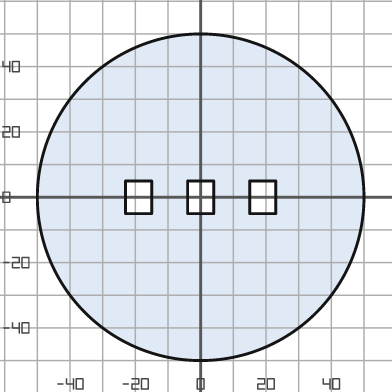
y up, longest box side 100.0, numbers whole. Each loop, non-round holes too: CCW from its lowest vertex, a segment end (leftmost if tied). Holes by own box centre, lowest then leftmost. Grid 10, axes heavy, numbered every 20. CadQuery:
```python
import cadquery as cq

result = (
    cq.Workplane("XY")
    .moveTo(0.0, 0.0)
    .circle(50.0)
    .moveTo(-23.0, -5.0)
    .lineTo(-15.0, -5.0)
    .lineTo(-15.0, 5.0)
    .lineTo(-23.0, 5.0)
    .close()
    .moveTo(-4.0, -5.0)
    .lineTo(4.0, -5.0)
    .lineTo(4.0, 5.0)
    .lineTo(-4.0, 5.0)
    .close()
    .moveTo(15.0, -5.0)
    .lineTo(23.0, -5.0)
    .lineTo(23.0, 5.0)
    .lineTo(15.0, 5.0)
    .close()
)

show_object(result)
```